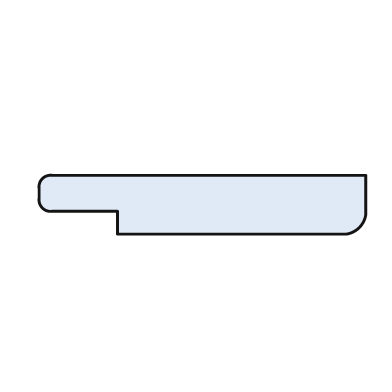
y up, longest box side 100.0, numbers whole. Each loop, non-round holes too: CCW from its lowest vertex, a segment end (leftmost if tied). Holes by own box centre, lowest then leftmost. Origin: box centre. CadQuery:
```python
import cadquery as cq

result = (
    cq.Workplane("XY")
    .moveTo(-26.0, -9.0)
    .lineTo(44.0, -9.0)
    .threePointArc((48.0, -7.0), (50.0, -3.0))
    .lineTo(50.0, 9.0)
    .lineTo(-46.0, 9.0)
    .threePointArc((-49.0, 8.0), (-50.0, 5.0))
    .lineTo(-50.0, 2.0)
    .threePointArc((-49.0, -1.0), (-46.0, -2.0))
    .lineTo(-26.0, -2.0)
    .close()
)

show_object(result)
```